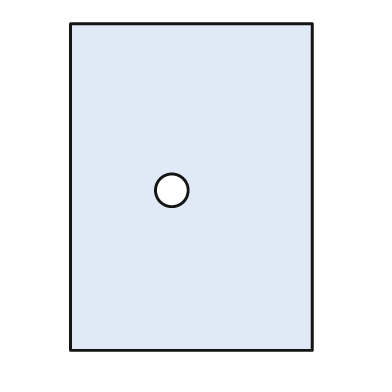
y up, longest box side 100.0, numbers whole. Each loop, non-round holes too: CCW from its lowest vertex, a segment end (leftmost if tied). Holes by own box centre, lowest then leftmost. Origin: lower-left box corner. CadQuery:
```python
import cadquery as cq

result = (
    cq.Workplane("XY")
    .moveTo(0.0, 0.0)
    .lineTo(74.0, 0.0)
    .lineTo(74.0, 100.0)
    .lineTo(0.0, 100.0)
    .close()
    .moveTo(31.0, 49.0)
    .circle(5.0)
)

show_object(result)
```